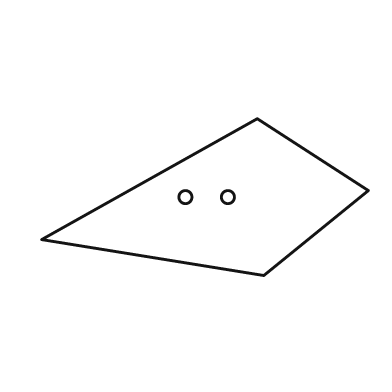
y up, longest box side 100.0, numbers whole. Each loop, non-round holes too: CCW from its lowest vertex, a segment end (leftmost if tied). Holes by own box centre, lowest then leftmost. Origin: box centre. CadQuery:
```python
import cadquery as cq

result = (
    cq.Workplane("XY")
    .moveTo(18.0, -24.0)
    .lineTo(50.0, 2.0)
    .lineTo(16.0, 24.0)
    .lineTo(-50.0, -13.0)
    .close()
    .moveTo(-6.0, 0.0)
    .circle(2.0)
    .moveTo(7.0, 0.0)
    .circle(2.0)
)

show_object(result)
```